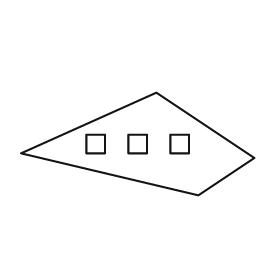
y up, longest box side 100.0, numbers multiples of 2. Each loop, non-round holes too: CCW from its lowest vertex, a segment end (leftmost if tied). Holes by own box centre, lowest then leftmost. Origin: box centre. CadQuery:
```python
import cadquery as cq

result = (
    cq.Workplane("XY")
    .moveTo(26.0, -22.0)
    .lineTo(50.0, -6.0)
    .lineTo(8.0, 22.0)
    .lineTo(-50.0, -4.0)
    .close()
    .moveTo(-22.0, -4.0)
    .lineTo(-14.0, -4.0)
    .lineTo(-14.0, 4.0)
    .lineTo(-22.0, 4.0)
    .close()
    .moveTo(-4.0, -4.0)
    .lineTo(4.0, -4.0)
    .lineTo(4.0, 4.0)
    .lineTo(-4.0, 4.0)
    .close()
    .moveTo(14.0, -4.0)
    .lineTo(22.0, -4.0)
    .lineTo(22.0, 4.0)
    .lineTo(14.0, 4.0)
    .close()
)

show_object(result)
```